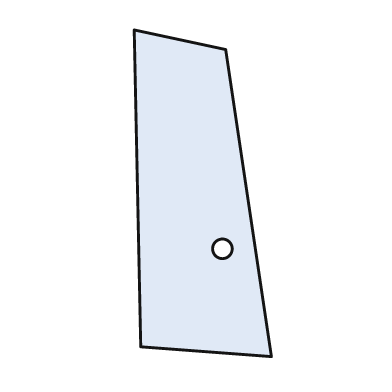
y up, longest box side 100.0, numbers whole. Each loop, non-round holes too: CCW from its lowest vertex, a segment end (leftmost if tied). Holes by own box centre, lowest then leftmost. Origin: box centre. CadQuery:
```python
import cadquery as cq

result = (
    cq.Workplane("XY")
    .moveTo(21.0, -50.0)
    .lineTo(7.0, 44.0)
    .lineTo(-21.0, 50.0)
    .lineTo(-19.0, -47.0)
    .close()
    .moveTo(6.0, -17.0)
    .circle(3.0)
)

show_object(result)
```